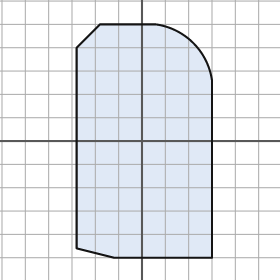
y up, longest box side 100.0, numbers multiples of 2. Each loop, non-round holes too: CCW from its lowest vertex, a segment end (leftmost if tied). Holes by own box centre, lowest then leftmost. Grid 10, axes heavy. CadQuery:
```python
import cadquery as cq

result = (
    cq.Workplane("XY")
    .moveTo(-12.0, -50.0)
    .lineTo(30.0, -50.0)
    .lineTo(30.0, 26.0)
    .threePointArc((22.0, 42.0), (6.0, 50.0))
    .lineTo(-18.0, 50.0)
    .lineTo(-28.0, 40.0)
    .lineTo(-28.0, -46.0)
    .close()
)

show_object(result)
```